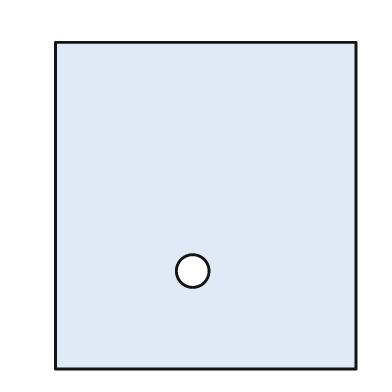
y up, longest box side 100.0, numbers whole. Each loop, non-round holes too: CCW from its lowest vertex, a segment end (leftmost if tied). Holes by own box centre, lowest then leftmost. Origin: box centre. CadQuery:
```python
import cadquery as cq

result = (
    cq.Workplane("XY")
    .moveTo(-46.0, -50.0)
    .lineTo(46.0, -50.0)
    .lineTo(46.0, 50.0)
    .lineTo(-46.0, 50.0)
    .close()
    .moveTo(-4.0, -20.0)
    .circle(5.0)
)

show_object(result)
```